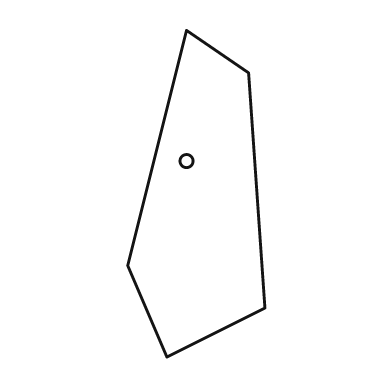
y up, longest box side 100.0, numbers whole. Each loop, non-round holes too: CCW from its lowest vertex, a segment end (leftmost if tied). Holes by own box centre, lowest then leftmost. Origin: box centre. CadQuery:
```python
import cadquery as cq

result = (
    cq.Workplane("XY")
    .moveTo(-9.0, -50.0)
    .lineTo(21.0, -35.0)
    .lineTo(16.0, 37.0)
    .lineTo(-3.0, 50.0)
    .lineTo(-21.0, -22.0)
    .close()
    .moveTo(-3.0, 10.0)
    .circle(2.0)
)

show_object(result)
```